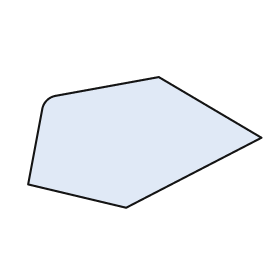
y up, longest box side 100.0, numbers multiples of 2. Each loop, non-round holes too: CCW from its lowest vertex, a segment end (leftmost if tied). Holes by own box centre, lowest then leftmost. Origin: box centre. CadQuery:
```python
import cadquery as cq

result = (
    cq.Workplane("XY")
    .moveTo(-8.0, -28.0)
    .lineTo(50.0, 2.0)
    .lineTo(6.0, 28.0)
    .lineTo(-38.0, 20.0)
    .threePointArc((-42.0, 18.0), (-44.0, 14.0))
    .lineTo(-50.0, -18.0)
    .close()
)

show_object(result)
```